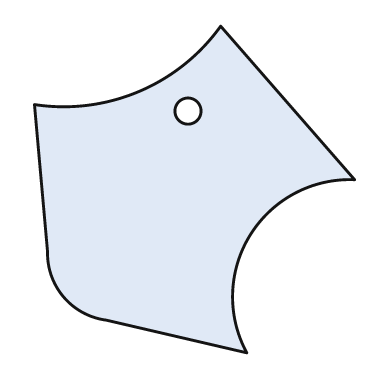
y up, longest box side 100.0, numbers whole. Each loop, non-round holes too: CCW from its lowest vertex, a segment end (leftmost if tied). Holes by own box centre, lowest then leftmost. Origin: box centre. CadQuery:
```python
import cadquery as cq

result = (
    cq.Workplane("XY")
    .moveTo(16.0, -50.0)
    .threePointArc((17.0, -14.0), (49.0, 3.0))
    .lineTo(8.0, 50.0)
    .threePointArc((-17.0, 30.0), (-49.0, 26.0))
    .lineTo(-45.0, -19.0)
    .threePointArc((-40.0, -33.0), (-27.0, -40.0))
    .close()
    .moveTo(-2.0, 24.0)
    .circle(4.0)
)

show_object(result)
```